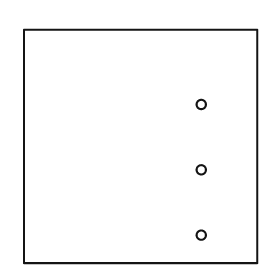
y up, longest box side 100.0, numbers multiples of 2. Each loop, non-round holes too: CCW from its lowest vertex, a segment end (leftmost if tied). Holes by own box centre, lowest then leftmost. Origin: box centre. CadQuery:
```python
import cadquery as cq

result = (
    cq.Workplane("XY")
    .moveTo(-50.0, -50.0)
    .lineTo(50.0, -50.0)
    .lineTo(50.0, 50.0)
    .lineTo(-50.0, 50.0)
    .close()
    .moveTo(26.0, -38.0)
    .circle(2.0)
    .moveTo(26.0, -10.0)
    .circle(2.0)
    .moveTo(26.0, 18.0)
    .circle(2.0)
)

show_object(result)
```